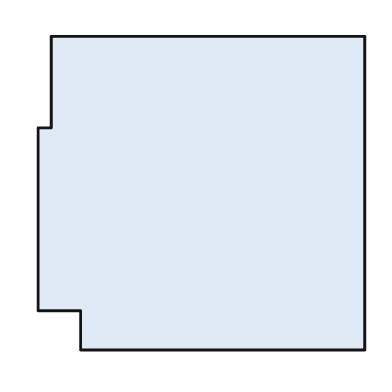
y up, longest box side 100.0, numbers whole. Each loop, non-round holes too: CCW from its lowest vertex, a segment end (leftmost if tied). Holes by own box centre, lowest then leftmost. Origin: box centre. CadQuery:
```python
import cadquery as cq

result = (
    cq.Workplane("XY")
    .moveTo(-37.0, -48.0)
    .lineTo(50.0, -48.0)
    .lineTo(50.0, 48.0)
    .lineTo(-46.0, 48.0)
    .lineTo(-46.0, 20.0)
    .lineTo(-50.0, 20.0)
    .lineTo(-50.0, -36.0)
    .lineTo(-37.0, -36.0)
    .close()
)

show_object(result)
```